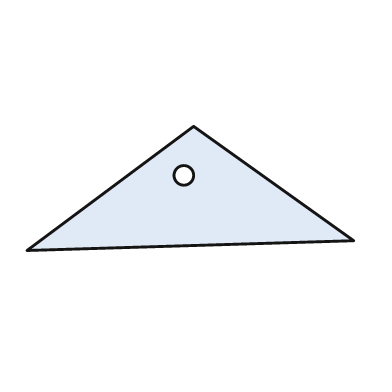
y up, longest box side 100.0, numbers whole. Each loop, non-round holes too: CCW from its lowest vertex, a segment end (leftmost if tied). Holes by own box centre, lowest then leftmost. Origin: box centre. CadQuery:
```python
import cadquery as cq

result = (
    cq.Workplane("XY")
    .moveTo(-50.0, -19.0)
    .lineTo(50.0, -16.0)
    .lineTo(1.0, 19.0)
    .close()
    .moveTo(-2.0, 4.0)
    .circle(3.0)
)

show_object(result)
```